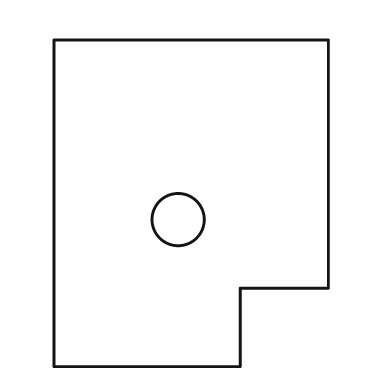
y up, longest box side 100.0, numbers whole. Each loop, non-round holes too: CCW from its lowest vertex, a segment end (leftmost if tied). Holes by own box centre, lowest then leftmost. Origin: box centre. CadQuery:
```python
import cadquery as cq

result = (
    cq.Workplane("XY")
    .moveTo(-42.0, -50.0)
    .lineTo(15.0, -50.0)
    .lineTo(15.0, -26.0)
    .lineTo(42.0, -26.0)
    .lineTo(42.0, 50.0)
    .lineTo(-42.0, 50.0)
    .close()
    .moveTo(-4.0, -5.0)
    .circle(8.0)
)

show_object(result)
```